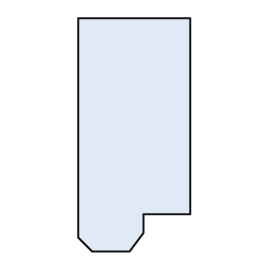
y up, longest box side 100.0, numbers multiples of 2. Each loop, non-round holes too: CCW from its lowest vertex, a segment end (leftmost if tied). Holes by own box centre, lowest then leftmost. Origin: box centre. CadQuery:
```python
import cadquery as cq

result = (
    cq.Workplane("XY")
    .moveTo(-18.0, -50.0)
    .lineTo(-2.0, -50.0)
    .lineTo(4.0, -42.0)
    .lineTo(4.0, -34.0)
    .lineTo(24.0, -34.0)
    .lineTo(24.0, 50.0)
    .lineTo(-24.0, 50.0)
    .lineTo(-24.0, -44.0)
    .close()
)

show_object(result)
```